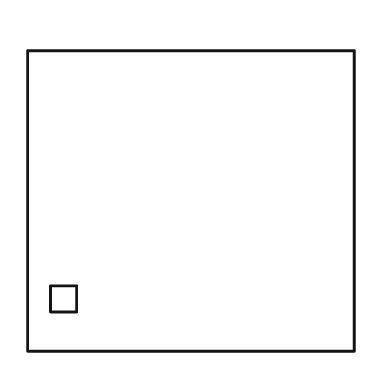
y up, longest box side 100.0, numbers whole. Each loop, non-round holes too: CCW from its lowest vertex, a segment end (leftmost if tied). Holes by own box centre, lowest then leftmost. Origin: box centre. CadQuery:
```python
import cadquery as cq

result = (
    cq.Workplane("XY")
    .moveTo(-50.0, -46.0)
    .lineTo(50.0, -46.0)
    .lineTo(50.0, 46.0)
    .lineTo(-50.0, 46.0)
    .close()
    .moveTo(-43.0, -34.0)
    .lineTo(-35.0, -34.0)
    .lineTo(-35.0, -26.0)
    .lineTo(-43.0, -26.0)
    .close()
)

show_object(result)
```